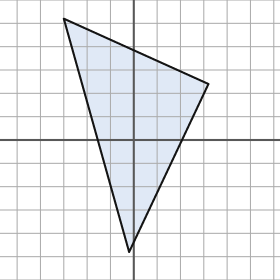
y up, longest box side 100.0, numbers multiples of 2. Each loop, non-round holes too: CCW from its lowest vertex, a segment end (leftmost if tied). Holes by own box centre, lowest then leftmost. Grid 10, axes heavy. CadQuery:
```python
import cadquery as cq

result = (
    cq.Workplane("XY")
    .moveTo(-2.0, -48.0)
    .lineTo(32.0, 24.0)
    .lineTo(-30.0, 52.0)
    .close()
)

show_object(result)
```